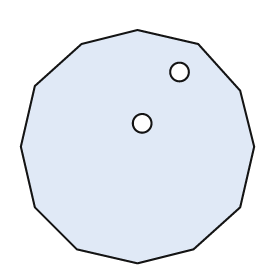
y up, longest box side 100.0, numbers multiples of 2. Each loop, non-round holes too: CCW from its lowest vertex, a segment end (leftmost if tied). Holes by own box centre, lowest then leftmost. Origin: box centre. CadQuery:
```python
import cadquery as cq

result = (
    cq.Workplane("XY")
    .moveTo(0.0, -50.0)
    .lineTo(24.0, -44.0)
    .lineTo(44.0, -26.0)
    .lineTo(50.0, 0.0)
    .lineTo(44.0, 24.0)
    .lineTo(26.0, 44.0)
    .lineTo(0.0, 50.0)
    .lineTo(-24.0, 44.0)
    .lineTo(-44.0, 26.0)
    .lineTo(-50.0, 0.0)
    .lineTo(-44.0, -26.0)
    .lineTo(-26.0, -44.0)
    .close()
    .moveTo(2.0, 10.0)
    .circle(4.0)
    .moveTo(18.0, 32.0)
    .circle(4.0)
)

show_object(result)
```